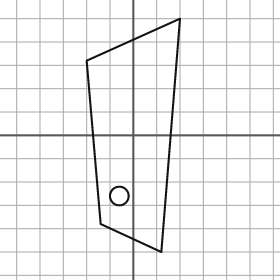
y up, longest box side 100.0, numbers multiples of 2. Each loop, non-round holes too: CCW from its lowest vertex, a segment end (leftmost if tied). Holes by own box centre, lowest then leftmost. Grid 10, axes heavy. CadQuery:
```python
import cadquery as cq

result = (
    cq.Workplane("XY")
    .moveTo(12.0, -50.0)
    .lineTo(20.0, 50.0)
    .lineTo(-20.0, 32.0)
    .lineTo(-14.0, -38.0)
    .close()
    .moveTo(-6.0, -26.0)
    .circle(4.0)
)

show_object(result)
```